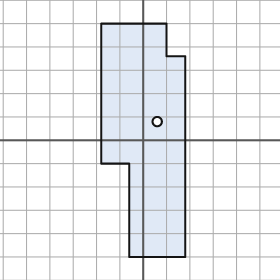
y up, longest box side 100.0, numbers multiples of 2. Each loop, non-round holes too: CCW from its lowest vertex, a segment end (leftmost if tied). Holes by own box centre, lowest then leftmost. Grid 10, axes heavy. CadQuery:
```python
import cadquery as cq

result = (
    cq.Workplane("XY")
    .moveTo(-6.0, -50.0)
    .lineTo(18.0, -50.0)
    .lineTo(18.0, 36.0)
    .lineTo(10.0, 36.0)
    .lineTo(10.0, 50.0)
    .lineTo(-18.0, 50.0)
    .lineTo(-18.0, -10.0)
    .lineTo(-6.0, -10.0)
    .close()
    .moveTo(6.0, 8.0)
    .circle(2.0)
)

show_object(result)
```